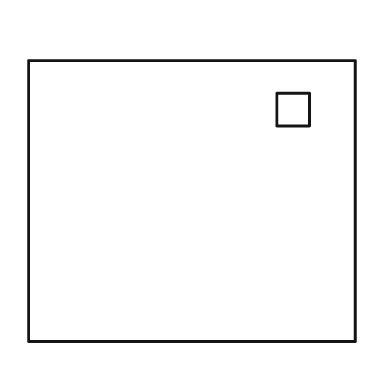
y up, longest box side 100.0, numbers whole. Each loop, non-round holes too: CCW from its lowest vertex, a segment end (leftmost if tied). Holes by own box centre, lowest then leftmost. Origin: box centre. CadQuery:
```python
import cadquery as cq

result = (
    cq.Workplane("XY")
    .moveTo(-50.0, -43.0)
    .lineTo(50.0, -43.0)
    .lineTo(50.0, 43.0)
    .lineTo(-50.0, 43.0)
    .close()
    .moveTo(26.0, 23.0)
    .lineTo(36.0, 23.0)
    .lineTo(36.0, 33.0)
    .lineTo(26.0, 33.0)
    .close()
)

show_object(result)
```